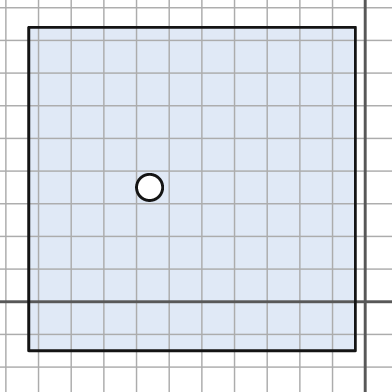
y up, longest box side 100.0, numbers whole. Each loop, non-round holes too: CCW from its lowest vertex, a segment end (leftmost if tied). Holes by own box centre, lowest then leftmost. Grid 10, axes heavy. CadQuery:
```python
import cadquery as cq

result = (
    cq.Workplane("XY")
    .moveTo(-103.0, -15.0)
    .lineTo(-3.0, -15.0)
    .lineTo(-3.0, 84.0)
    .lineTo(-103.0, 84.0)
    .close()
    .moveTo(-66.0, 35.0)
    .circle(4.0)
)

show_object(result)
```